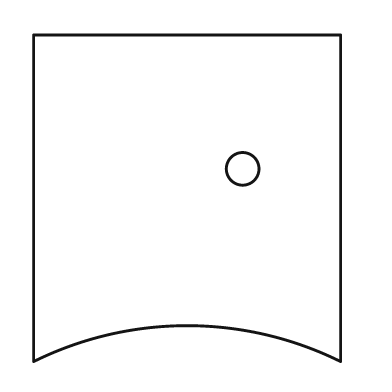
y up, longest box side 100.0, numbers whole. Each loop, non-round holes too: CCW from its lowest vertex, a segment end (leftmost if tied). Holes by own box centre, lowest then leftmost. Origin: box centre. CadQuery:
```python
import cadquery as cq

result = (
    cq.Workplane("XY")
    .moveTo(-47.0, -50.0)
    .threePointArc((0.0, -39.0), (47.0, -50.0))
    .lineTo(47.0, 50.0)
    .lineTo(-47.0, 50.0)
    .close()
    .moveTo(17.0, 9.0)
    .circle(5.0)
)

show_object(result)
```